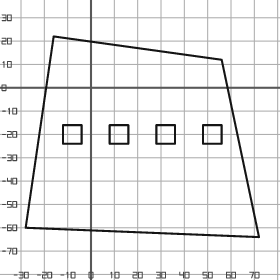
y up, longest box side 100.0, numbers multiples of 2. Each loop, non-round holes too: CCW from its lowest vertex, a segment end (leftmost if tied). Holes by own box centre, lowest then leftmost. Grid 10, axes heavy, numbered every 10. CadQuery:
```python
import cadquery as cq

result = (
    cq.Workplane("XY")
    .moveTo(72.0, -64.0)
    .lineTo(56.0, 12.0)
    .lineTo(-16.0, 22.0)
    .lineTo(-28.0, -60.0)
    .close()
    .moveTo(-12.0, -24.0)
    .lineTo(-4.0, -24.0)
    .lineTo(-4.0, -16.0)
    .lineTo(-12.0, -16.0)
    .close()
    .moveTo(8.0, -24.0)
    .lineTo(16.0, -24.0)
    .lineTo(16.0, -16.0)
    .lineTo(8.0, -16.0)
    .close()
    .moveTo(28.0, -24.0)
    .lineTo(36.0, -24.0)
    .lineTo(36.0, -16.0)
    .lineTo(28.0, -16.0)
    .close()
    .moveTo(48.0, -24.0)
    .lineTo(56.0, -24.0)
    .lineTo(56.0, -16.0)
    .lineTo(48.0, -16.0)
    .close()
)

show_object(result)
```